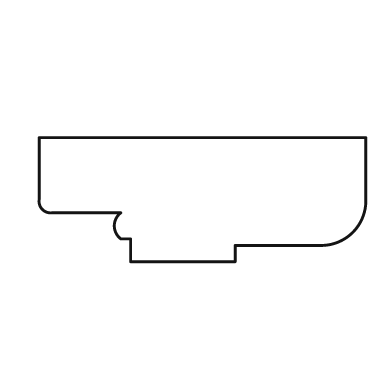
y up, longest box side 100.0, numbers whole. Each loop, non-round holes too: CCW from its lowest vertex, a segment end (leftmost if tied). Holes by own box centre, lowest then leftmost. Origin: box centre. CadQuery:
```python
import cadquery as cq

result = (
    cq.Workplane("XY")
    .moveTo(-22.0, -19.0)
    .lineTo(10.0, -19.0)
    .lineTo(10.0, -14.0)
    .lineTo(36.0, -14.0)
    .threePointArc((46.0, -10.0), (50.0, 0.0))
    .lineTo(50.0, 19.0)
    .lineTo(-50.0, 19.0)
    .lineTo(-50.0, 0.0)
    .threePointArc((-49.0, -3.0), (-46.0, -4.0))
    .lineTo(-25.0, -4.0)
    .threePointArc((-27.0, -8.0), (-25.0, -12.0))
    .lineTo(-22.0, -12.0)
    .close()
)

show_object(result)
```